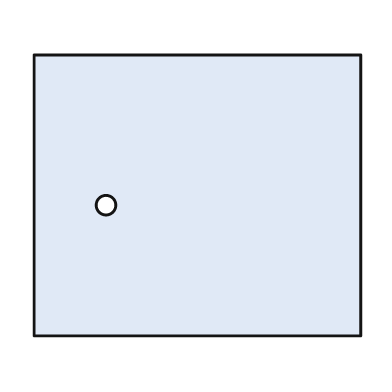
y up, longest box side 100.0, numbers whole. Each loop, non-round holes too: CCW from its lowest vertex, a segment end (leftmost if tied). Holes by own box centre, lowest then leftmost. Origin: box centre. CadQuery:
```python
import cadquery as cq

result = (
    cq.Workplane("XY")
    .moveTo(-50.0, -43.0)
    .lineTo(50.0, -43.0)
    .lineTo(50.0, 43.0)
    .lineTo(-50.0, 43.0)
    .close()
    .moveTo(-28.0, -3.0)
    .circle(3.0)
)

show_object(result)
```